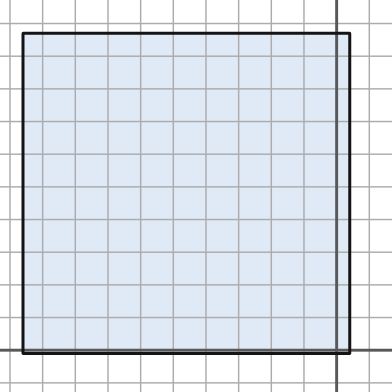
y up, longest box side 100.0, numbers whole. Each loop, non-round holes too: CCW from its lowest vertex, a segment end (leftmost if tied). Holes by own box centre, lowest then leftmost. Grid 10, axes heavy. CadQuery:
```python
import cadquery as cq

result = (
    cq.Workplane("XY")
    .moveTo(-96.0, -1.0)
    .lineTo(4.0, -1.0)
    .lineTo(4.0, 97.0)
    .lineTo(-96.0, 97.0)
    .close()
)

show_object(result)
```